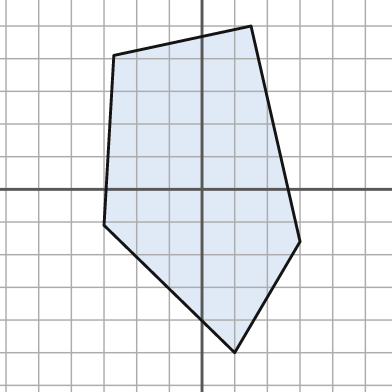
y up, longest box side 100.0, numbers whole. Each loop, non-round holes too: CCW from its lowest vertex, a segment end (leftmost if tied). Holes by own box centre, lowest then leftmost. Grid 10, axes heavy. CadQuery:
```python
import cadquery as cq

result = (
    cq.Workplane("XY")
    .moveTo(10.0, -50.0)
    .lineTo(30.0, -16.0)
    .lineTo(15.0, 50.0)
    .lineTo(-27.0, 41.0)
    .lineTo(-30.0, -11.0)
    .close()
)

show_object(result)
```